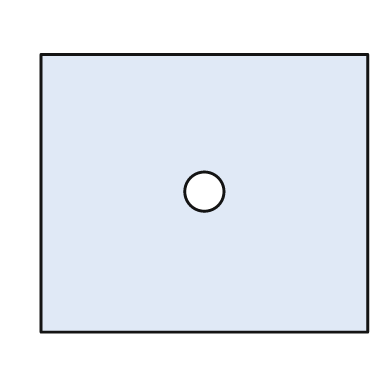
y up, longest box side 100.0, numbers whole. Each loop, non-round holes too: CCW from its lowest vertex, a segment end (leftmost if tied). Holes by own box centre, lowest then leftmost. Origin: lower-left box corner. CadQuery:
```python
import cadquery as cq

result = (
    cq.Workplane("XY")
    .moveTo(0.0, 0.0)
    .lineTo(100.0, 0.0)
    .lineTo(100.0, 85.0)
    .lineTo(0.0, 85.0)
    .close()
    .moveTo(50.0, 43.0)
    .circle(6.0)
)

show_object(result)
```